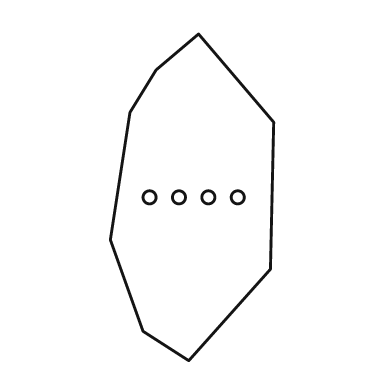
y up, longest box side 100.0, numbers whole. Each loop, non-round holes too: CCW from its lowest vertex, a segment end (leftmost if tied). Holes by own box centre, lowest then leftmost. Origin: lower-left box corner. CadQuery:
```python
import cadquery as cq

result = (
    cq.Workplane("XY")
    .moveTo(24.0, 0.0)
    .lineTo(49.0, 28.0)
    .lineTo(50.0, 73.0)
    .lineTo(27.0, 100.0)
    .lineTo(14.0, 89.0)
    .lineTo(6.0, 76.0)
    .lineTo(0.0, 37.0)
    .lineTo(10.0, 9.0)
    .close()
    .moveTo(12.0, 50.0)
    .circle(2.0)
    .moveTo(21.0, 50.0)
    .circle(2.0)
    .moveTo(30.0, 50.0)
    .circle(2.0)
    .moveTo(39.0, 50.0)
    .circle(2.0)
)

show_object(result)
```